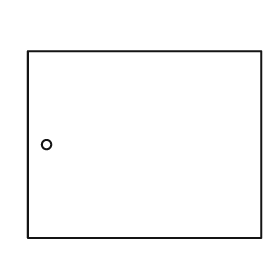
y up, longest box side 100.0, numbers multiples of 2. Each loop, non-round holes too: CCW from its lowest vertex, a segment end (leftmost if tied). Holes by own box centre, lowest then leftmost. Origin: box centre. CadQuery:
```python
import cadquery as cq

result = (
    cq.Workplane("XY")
    .moveTo(-50.0, -40.0)
    .lineTo(50.0, -40.0)
    .lineTo(50.0, 40.0)
    .lineTo(-50.0, 40.0)
    .close()
    .moveTo(-42.0, 0.0)
    .circle(2.0)
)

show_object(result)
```